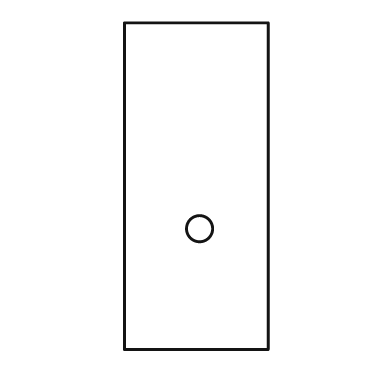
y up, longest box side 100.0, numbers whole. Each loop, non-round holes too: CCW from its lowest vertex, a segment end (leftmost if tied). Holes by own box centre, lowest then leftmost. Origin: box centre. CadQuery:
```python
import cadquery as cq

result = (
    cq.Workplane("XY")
    .moveTo(-22.0, -50.0)
    .lineTo(22.0, -50.0)
    .lineTo(22.0, 50.0)
    .lineTo(-22.0, 50.0)
    .close()
    .moveTo(1.0, -13.0)
    .circle(4.0)
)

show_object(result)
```